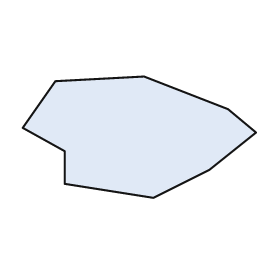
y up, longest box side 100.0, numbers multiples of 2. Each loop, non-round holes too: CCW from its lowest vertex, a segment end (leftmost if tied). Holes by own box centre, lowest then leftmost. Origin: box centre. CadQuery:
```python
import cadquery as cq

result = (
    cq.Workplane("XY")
    .moveTo(6.0, -26.0)
    .lineTo(30.0, -14.0)
    .lineTo(50.0, 2.0)
    .lineTo(38.0, 12.0)
    .lineTo(2.0, 26.0)
    .lineTo(-36.0, 24.0)
    .lineTo(-50.0, 4.0)
    .lineTo(-32.0, -6.0)
    .lineTo(-32.0, -20.0)
    .close()
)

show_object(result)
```